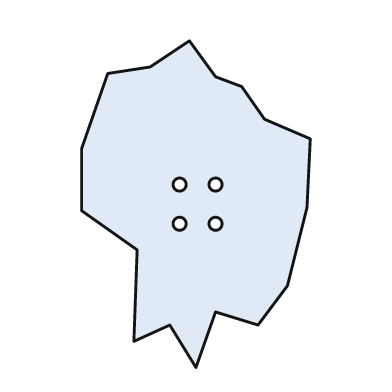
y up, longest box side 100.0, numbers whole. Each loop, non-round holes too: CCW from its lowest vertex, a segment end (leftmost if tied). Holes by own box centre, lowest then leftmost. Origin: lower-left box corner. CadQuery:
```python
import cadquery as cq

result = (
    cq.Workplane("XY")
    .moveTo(35.0, 0.0)
    .lineTo(41.0, 17.0)
    .lineTo(54.0, 13.0)
    .lineTo(63.0, 25.0)
    .lineTo(69.0, 49.0)
    .lineTo(70.0, 70.0)
    .lineTo(56.0, 76.0)
    .lineTo(49.0, 86.0)
    .lineTo(41.0, 89.0)
    .lineTo(33.0, 100.0)
    .lineTo(21.0, 92.0)
    .lineTo(8.0, 90.0)
    .lineTo(0.0, 67.0)
    .lineTo(0.0, 48.0)
    .lineTo(17.0, 36.0)
    .lineTo(16.0, 8.0)
    .lineTo(27.0, 13.0)
    .close()
    .moveTo(30.0, 44.0)
    .circle(2.0)
    .moveTo(41.0, 44.0)
    .circle(2.0)
    .moveTo(30.0, 56.0)
    .circle(2.0)
    .moveTo(41.0, 56.0)
    .circle(2.0)
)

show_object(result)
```